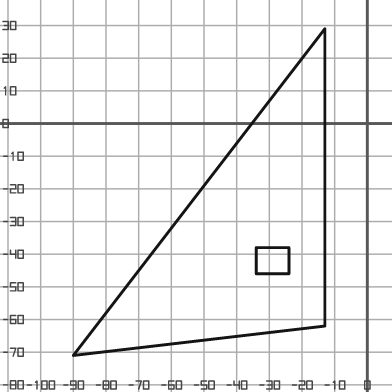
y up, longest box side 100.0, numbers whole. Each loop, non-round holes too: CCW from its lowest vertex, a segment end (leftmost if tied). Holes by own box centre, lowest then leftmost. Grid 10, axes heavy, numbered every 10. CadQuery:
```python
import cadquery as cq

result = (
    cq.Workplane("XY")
    .moveTo(-90.0, -71.0)
    .lineTo(-13.0, -62.0)
    .lineTo(-13.0, 29.0)
    .close()
    .moveTo(-34.0, -46.0)
    .lineTo(-24.0, -46.0)
    .lineTo(-24.0, -38.0)
    .lineTo(-34.0, -38.0)
    .close()
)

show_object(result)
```